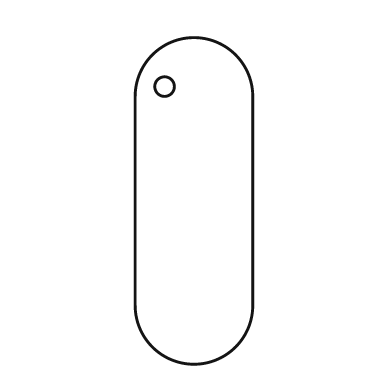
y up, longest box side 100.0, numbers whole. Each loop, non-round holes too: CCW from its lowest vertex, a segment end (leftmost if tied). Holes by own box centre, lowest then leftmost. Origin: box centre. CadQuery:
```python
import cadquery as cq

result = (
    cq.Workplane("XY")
    .moveTo(-18.0, -32.0)
    .threePointArc((0.0, -50.0), (18.0, -32.0))
    .lineTo(18.0, 32.0)
    .threePointArc((0.0, 50.0), (-18.0, 32.0))
    .close()
    .moveTo(-9.0, 35.0)
    .circle(3.0)
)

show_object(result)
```